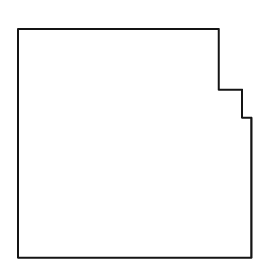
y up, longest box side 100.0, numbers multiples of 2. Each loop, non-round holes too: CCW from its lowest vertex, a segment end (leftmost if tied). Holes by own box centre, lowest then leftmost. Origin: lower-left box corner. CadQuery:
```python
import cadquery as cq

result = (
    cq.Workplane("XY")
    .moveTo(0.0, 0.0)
    .lineTo(100.0, 0.0)
    .lineTo(100.0, 60.0)
    .lineTo(96.0, 60.0)
    .lineTo(96.0, 72.0)
    .lineTo(86.0, 72.0)
    .lineTo(86.0, 98.0)
    .lineTo(0.0, 98.0)
    .close()
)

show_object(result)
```